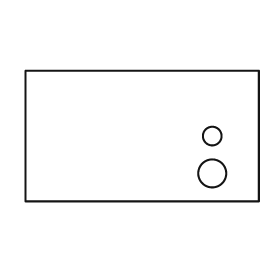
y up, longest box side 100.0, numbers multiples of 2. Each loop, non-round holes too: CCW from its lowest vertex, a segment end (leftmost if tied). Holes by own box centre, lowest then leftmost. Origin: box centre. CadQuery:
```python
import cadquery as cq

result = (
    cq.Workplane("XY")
    .moveTo(-50.0, -28.0)
    .lineTo(50.0, -28.0)
    .lineTo(50.0, 28.0)
    .lineTo(-50.0, 28.0)
    .close()
    .moveTo(30.0, -16.0)
    .circle(6.0)
    .moveTo(30.0, 0.0)
    .circle(4.0)
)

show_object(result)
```